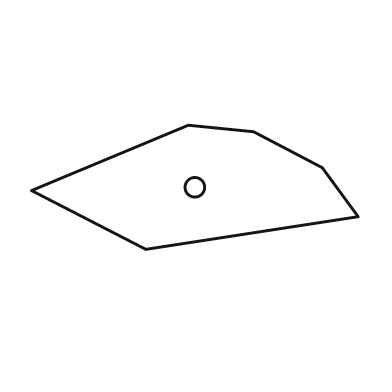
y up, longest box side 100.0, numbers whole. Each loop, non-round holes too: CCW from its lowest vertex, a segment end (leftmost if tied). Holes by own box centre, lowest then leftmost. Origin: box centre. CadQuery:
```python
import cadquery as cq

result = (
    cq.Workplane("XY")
    .moveTo(-15.0, -19.0)
    .lineTo(50.0, -9.0)
    .lineTo(39.0, 6.0)
    .lineTo(18.0, 17.0)
    .lineTo(-2.0, 19.0)
    .lineTo(-50.0, -1.0)
    .close()
    .moveTo(0.0, 0.0)
    .circle(3.0)
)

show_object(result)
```